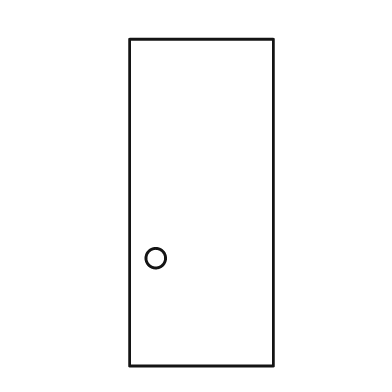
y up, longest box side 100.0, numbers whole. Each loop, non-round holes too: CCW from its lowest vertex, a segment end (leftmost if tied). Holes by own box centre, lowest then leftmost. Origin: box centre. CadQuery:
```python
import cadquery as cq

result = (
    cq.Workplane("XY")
    .moveTo(-22.0, -50.0)
    .lineTo(22.0, -50.0)
    .lineTo(22.0, 50.0)
    .lineTo(-22.0, 50.0)
    .close()
    .moveTo(-14.0, -17.0)
    .circle(3.0)
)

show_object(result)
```